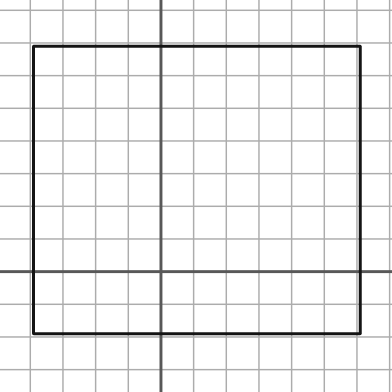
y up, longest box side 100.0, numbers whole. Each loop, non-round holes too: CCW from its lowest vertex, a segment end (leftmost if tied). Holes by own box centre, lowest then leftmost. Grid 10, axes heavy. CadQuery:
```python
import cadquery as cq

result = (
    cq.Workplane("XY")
    .moveTo(-39.0, -19.0)
    .lineTo(61.0, -19.0)
    .lineTo(61.0, 69.0)
    .lineTo(-39.0, 69.0)
    .close()
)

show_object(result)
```